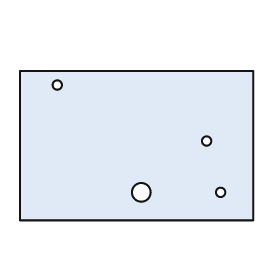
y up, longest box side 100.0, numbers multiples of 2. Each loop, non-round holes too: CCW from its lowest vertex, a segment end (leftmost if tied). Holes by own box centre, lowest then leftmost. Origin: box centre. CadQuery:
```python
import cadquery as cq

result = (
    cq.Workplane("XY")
    .moveTo(-50.0, -32.0)
    .lineTo(50.0, -32.0)
    .lineTo(50.0, 32.0)
    .lineTo(-50.0, 32.0)
    .close()
    .moveTo(2.0, -20.0)
    .circle(4.0)
    .moveTo(36.0, -20.0)
    .circle(2.0)
    .moveTo(30.0, 2.0)
    .circle(2.0)
    .moveTo(-34.0, 26.0)
    .circle(2.0)
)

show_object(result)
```